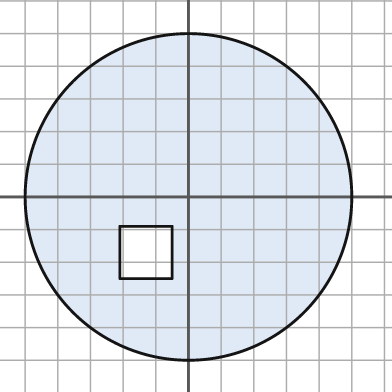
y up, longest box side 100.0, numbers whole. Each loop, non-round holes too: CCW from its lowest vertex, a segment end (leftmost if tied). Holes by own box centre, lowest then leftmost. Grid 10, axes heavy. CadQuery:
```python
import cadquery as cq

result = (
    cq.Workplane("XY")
    .moveTo(0.0, 0.0)
    .circle(50.0)
    .moveTo(-21.0, -25.0)
    .lineTo(-5.0, -25.0)
    .lineTo(-5.0, -9.0)
    .lineTo(-21.0, -9.0)
    .close()
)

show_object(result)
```